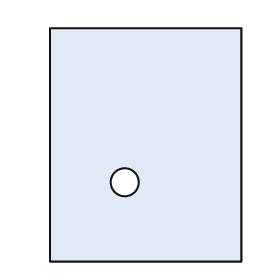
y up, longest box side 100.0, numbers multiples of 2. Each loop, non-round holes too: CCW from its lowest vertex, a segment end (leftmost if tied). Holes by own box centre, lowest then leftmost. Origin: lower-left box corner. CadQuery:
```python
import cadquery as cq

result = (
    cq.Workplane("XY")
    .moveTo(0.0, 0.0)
    .lineTo(82.0, 0.0)
    .lineTo(82.0, 100.0)
    .lineTo(0.0, 100.0)
    .close()
    .moveTo(32.0, 34.0)
    .circle(6.0)
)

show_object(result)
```